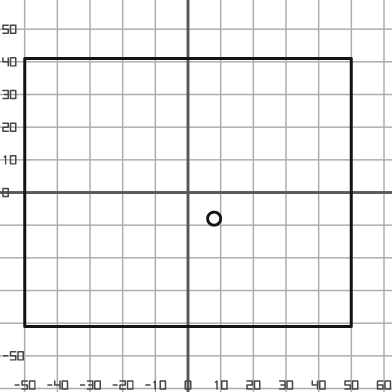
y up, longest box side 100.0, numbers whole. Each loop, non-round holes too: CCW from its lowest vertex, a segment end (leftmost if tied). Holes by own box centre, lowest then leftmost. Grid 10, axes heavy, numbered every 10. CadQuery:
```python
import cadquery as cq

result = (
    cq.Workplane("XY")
    .moveTo(-50.0, -41.0)
    .lineTo(50.0, -41.0)
    .lineTo(50.0, 41.0)
    .lineTo(-50.0, 41.0)
    .close()
    .moveTo(8.0, -8.0)
    .circle(2.0)
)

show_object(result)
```